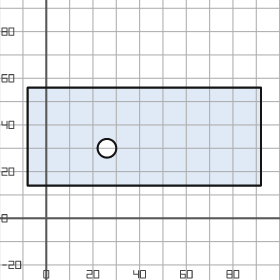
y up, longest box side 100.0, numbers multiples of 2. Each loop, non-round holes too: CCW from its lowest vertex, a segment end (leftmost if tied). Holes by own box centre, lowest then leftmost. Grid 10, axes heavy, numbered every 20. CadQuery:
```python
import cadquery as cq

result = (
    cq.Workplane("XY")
    .moveTo(-8.0, 14.0)
    .lineTo(92.0, 14.0)
    .lineTo(92.0, 56.0)
    .lineTo(-8.0, 56.0)
    .close()
    .moveTo(26.0, 30.0)
    .circle(4.0)
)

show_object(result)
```